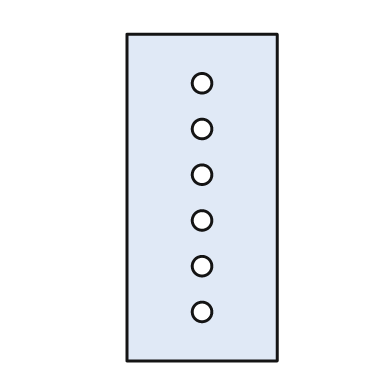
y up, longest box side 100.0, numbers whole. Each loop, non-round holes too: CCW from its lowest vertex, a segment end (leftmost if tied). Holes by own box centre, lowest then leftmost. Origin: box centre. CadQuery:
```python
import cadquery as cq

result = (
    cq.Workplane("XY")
    .moveTo(-23.0, -50.0)
    .lineTo(23.0, -50.0)
    .lineTo(23.0, 50.0)
    .lineTo(-23.0, 50.0)
    .close()
    .moveTo(0.0, -35.0)
    .circle(3.0)
    .moveTo(0.0, -21.0)
    .circle(3.0)
    .moveTo(0.0, -7.0)
    .circle(3.0)
    .moveTo(0.0, 7.0)
    .circle(3.0)
    .moveTo(0.0, 21.0)
    .circle(3.0)
    .moveTo(0.0, 35.0)
    .circle(3.0)
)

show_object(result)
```